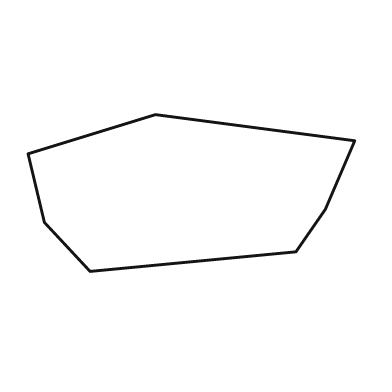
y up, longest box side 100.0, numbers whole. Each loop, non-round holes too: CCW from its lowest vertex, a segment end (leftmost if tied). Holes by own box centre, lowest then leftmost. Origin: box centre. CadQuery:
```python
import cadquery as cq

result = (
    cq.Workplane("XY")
    .moveTo(-31.0, -24.0)
    .lineTo(32.0, -18.0)
    .lineTo(41.0, -5.0)
    .lineTo(50.0, 16.0)
    .lineTo(-11.0, 24.0)
    .lineTo(-50.0, 12.0)
    .lineTo(-45.0, -9.0)
    .close()
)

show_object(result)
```